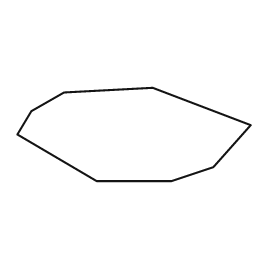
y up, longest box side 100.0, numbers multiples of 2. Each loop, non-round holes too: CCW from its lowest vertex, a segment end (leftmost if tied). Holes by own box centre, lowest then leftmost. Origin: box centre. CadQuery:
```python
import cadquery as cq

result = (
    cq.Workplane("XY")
    .moveTo(-16.0, -20.0)
    .lineTo(16.0, -20.0)
    .lineTo(34.0, -14.0)
    .lineTo(50.0, 4.0)
    .lineTo(8.0, 20.0)
    .lineTo(-30.0, 18.0)
    .lineTo(-44.0, 10.0)
    .lineTo(-50.0, 0.0)
    .close()
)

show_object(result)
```